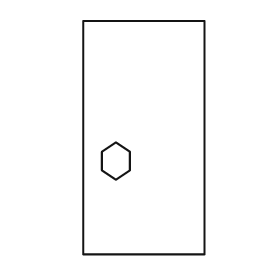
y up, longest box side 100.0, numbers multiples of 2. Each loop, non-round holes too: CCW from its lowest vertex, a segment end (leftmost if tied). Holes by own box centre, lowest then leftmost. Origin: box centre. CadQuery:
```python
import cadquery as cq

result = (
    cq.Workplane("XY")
    .moveTo(-26.0, -50.0)
    .lineTo(26.0, -50.0)
    .lineTo(26.0, 50.0)
    .lineTo(-26.0, 50.0)
    .close()
    .moveTo(-12.0, -18.0)
    .lineTo(-6.0, -14.0)
    .lineTo(-6.0, -6.0)
    .lineTo(-12.0, -2.0)
    .lineTo(-18.0, -6.0)
    .lineTo(-18.0, -14.0)
    .close()
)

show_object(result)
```